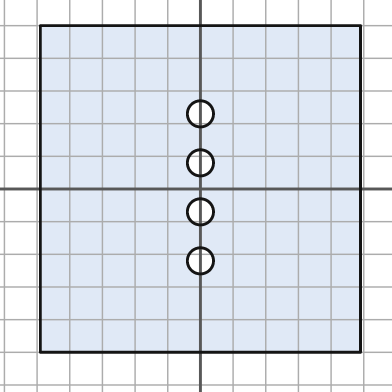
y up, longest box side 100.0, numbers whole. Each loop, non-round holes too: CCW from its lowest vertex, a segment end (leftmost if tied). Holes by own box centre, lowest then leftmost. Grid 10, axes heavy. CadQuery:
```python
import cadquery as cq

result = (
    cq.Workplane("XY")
    .moveTo(-49.0, -50.0)
    .lineTo(49.0, -50.0)
    .lineTo(49.0, 50.0)
    .lineTo(-49.0, 50.0)
    .close()
    .moveTo(0.0, -22.0)
    .circle(4.0)
    .moveTo(0.0, -7.0)
    .circle(4.0)
    .moveTo(0.0, 8.0)
    .circle(4.0)
    .moveTo(0.0, 23.0)
    .circle(4.0)
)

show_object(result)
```